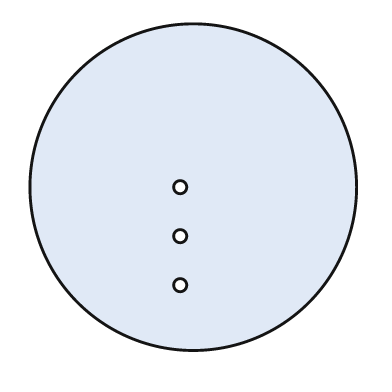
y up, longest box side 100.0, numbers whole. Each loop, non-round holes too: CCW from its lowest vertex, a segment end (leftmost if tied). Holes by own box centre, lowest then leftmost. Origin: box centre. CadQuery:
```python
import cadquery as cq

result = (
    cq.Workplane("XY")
    .moveTo(0.0, 0.0)
    .circle(50.0)
    .moveTo(-4.0, -30.0)
    .circle(2.0)
    .moveTo(-4.0, -15.0)
    .circle(2.0)
    .moveTo(-4.0, 0.0)
    .circle(2.0)
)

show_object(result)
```